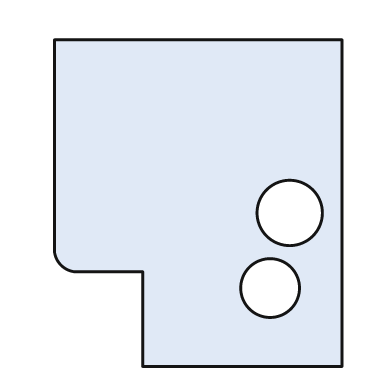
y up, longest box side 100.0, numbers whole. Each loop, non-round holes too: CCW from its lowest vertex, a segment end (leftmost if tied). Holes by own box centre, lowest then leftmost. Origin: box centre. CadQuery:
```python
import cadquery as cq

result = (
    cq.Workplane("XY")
    .moveTo(-17.0, -50.0)
    .lineTo(44.0, -50.0)
    .lineTo(44.0, 50.0)
    .lineTo(-44.0, 50.0)
    .lineTo(-44.0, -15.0)
    .threePointArc((-42.0, -19.0), (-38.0, -21.0))
    .lineTo(-17.0, -21.0)
    .close()
    .moveTo(22.0, -26.0)
    .circle(9.0)
    .moveTo(28.0, -3.0)
    .circle(10.0)
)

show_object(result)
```